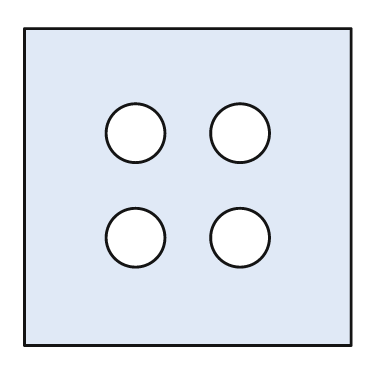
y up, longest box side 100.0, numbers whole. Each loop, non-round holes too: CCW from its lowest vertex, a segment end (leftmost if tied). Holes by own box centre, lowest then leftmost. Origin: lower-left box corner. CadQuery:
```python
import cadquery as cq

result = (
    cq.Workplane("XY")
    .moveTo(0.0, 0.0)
    .lineTo(100.0, 0.0)
    .lineTo(100.0, 97.0)
    .lineTo(0.0, 97.0)
    .close()
    .moveTo(34.0, 33.0)
    .circle(9.0)
    .moveTo(66.0, 33.0)
    .circle(9.0)
    .moveTo(34.0, 65.0)
    .circle(9.0)
    .moveTo(66.0, 65.0)
    .circle(9.0)
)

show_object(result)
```